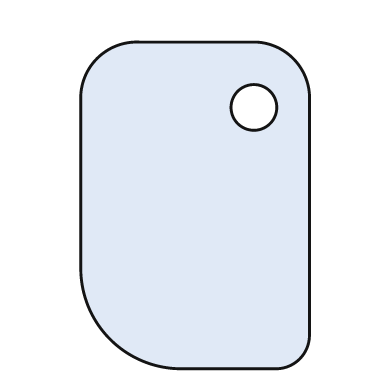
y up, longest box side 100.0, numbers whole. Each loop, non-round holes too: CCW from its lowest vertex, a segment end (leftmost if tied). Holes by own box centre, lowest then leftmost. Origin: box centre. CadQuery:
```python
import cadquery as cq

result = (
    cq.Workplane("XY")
    .moveTo(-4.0, -50.0)
    .lineTo(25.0, -50.0)
    .threePointArc((32.0, -47.0), (35.0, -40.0))
    .lineTo(35.0, 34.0)
    .threePointArc((30.0, 45.0), (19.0, 50.0))
    .lineTo(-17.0, 50.0)
    .threePointArc((-30.0, 45.0), (-35.0, 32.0))
    .lineTo(-35.0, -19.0)
    .threePointArc((-26.0, -41.0), (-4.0, -50.0))
    .close()
    .moveTo(18.0, 30.0)
    .circle(7.0)
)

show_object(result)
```